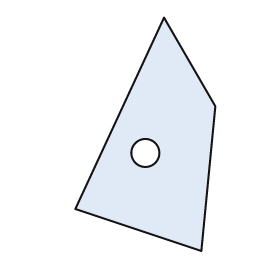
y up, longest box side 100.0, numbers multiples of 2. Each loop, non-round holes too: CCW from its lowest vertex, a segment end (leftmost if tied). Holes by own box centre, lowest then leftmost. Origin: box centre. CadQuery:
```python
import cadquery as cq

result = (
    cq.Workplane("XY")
    .moveTo(24.0, -50.0)
    .lineTo(30.0, 12.0)
    .lineTo(8.0, 50.0)
    .lineTo(-30.0, -32.0)
    .close()
    .moveTo(0.0, -8.0)
    .circle(6.0)
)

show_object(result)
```